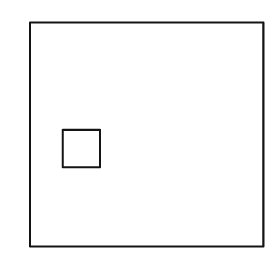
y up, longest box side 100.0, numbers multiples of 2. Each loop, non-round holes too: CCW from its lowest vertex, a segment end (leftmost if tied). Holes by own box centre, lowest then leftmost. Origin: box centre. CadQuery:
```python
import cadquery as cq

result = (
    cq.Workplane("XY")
    .moveTo(-50.0, -48.0)
    .lineTo(50.0, -48.0)
    .lineTo(50.0, 48.0)
    .lineTo(-50.0, 48.0)
    .close()
    .moveTo(-36.0, -14.0)
    .lineTo(-20.0, -14.0)
    .lineTo(-20.0, 2.0)
    .lineTo(-36.0, 2.0)
    .close()
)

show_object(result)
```